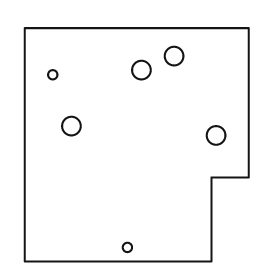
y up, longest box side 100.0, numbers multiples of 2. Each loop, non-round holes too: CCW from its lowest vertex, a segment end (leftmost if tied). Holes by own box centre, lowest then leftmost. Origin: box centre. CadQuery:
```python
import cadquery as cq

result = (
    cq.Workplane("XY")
    .moveTo(-48.0, -50.0)
    .lineTo(32.0, -50.0)
    .lineTo(32.0, -14.0)
    .lineTo(48.0, -14.0)
    .lineTo(48.0, 50.0)
    .lineTo(-48.0, 50.0)
    .close()
    .moveTo(-4.0, -44.0)
    .circle(2.0)
    .moveTo(34.0, 4.0)
    .circle(4.0)
    .moveTo(-28.0, 8.0)
    .circle(4.0)
    .moveTo(-36.0, 30.0)
    .circle(2.0)
    .moveTo(2.0, 32.0)
    .circle(4.0)
    .moveTo(16.0, 38.0)
    .circle(4.0)
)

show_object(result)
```